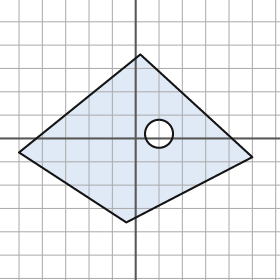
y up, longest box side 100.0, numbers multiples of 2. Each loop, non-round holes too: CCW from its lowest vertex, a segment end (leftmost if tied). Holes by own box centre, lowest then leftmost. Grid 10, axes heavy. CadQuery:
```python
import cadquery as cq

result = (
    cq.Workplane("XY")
    .moveTo(-4.0, -36.0)
    .lineTo(50.0, -8.0)
    .lineTo(2.0, 36.0)
    .lineTo(-50.0, -6.0)
    .close()
    .moveTo(10.0, 2.0)
    .circle(6.0)
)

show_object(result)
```